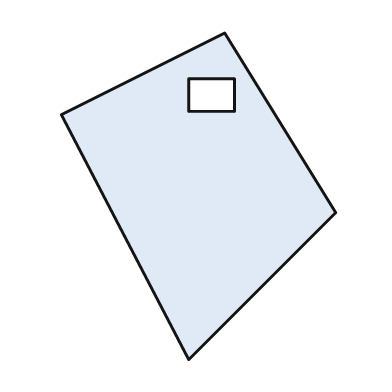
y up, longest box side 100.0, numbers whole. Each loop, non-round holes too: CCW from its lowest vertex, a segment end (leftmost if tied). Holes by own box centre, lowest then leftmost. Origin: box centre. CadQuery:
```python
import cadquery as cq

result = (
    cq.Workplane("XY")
    .moveTo(-3.0, -50.0)
    .lineTo(42.0, -5.0)
    .lineTo(8.0, 50.0)
    .lineTo(-42.0, 25.0)
    .close()
    .moveTo(-3.0, 26.0)
    .lineTo(11.0, 26.0)
    .lineTo(11.0, 36.0)
    .lineTo(-3.0, 36.0)
    .close()
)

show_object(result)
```